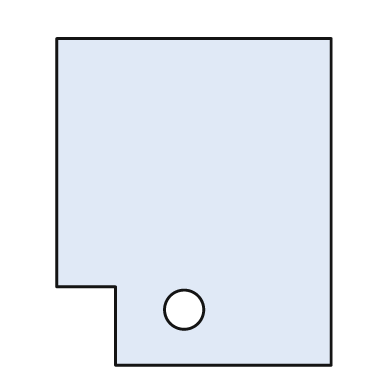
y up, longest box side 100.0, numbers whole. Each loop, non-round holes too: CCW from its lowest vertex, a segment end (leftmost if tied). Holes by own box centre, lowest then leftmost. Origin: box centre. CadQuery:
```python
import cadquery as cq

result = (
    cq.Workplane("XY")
    .moveTo(-24.0, -50.0)
    .lineTo(42.0, -50.0)
    .lineTo(42.0, 50.0)
    .lineTo(-42.0, 50.0)
    .lineTo(-42.0, -26.0)
    .lineTo(-24.0, -26.0)
    .close()
    .moveTo(-3.0, -33.0)
    .circle(6.0)
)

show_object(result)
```